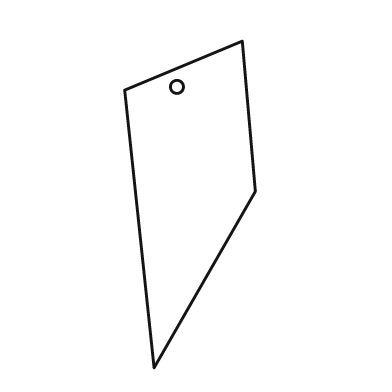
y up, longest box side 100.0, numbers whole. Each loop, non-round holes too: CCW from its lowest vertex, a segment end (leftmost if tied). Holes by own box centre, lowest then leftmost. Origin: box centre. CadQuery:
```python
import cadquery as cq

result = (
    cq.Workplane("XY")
    .moveTo(-11.0, -50.0)
    .lineTo(20.0, 4.0)
    .lineTo(16.0, 50.0)
    .lineTo(-20.0, 35.0)
    .close()
    .moveTo(-4.0, 36.0)
    .circle(2.0)
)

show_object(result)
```